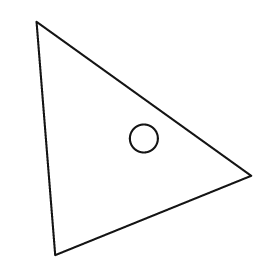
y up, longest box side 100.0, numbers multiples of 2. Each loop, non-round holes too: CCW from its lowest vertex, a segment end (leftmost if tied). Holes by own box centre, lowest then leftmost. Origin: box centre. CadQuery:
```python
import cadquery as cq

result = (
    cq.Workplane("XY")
    .moveTo(-38.0, -50.0)
    .lineTo(46.0, -16.0)
    .lineTo(-46.0, 50.0)
    .close()
    .moveTo(0.0, 0.0)
    .circle(6.0)
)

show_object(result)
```